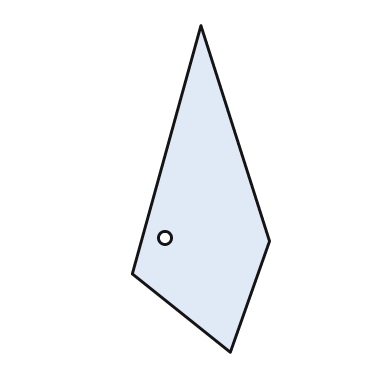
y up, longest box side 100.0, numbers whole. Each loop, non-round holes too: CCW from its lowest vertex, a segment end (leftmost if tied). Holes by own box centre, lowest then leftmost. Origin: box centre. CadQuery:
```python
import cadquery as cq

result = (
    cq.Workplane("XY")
    .moveTo(9.0, -50.0)
    .lineTo(21.0, -16.0)
    .lineTo(0.0, 50.0)
    .lineTo(-21.0, -26.0)
    .close()
    .moveTo(-11.0, -15.0)
    .circle(2.0)
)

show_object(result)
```